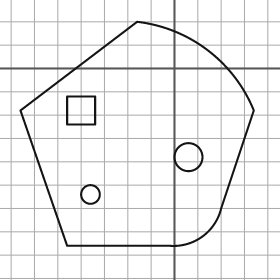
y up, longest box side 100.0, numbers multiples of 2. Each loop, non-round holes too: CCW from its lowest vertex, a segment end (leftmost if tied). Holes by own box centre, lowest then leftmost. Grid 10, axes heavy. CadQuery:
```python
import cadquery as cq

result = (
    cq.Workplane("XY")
    .moveTo(-46.0, -76.0)
    .lineTo(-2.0, -76.0)
    .threePointArc((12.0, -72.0), (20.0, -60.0))
    .lineTo(34.0, -18.0)
    .threePointArc((14.0, 8.0), (-16.0, 20.0))
    .lineTo(-66.0, -18.0)
    .close()
    .moveTo(-36.0, -54.0)
    .circle(4.0)
    .moveTo(6.0, -38.0)
    .circle(6.0)
    .moveTo(-46.0, -24.0)
    .lineTo(-34.0, -24.0)
    .lineTo(-34.0, -12.0)
    .lineTo(-46.0, -12.0)
    .close()
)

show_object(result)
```